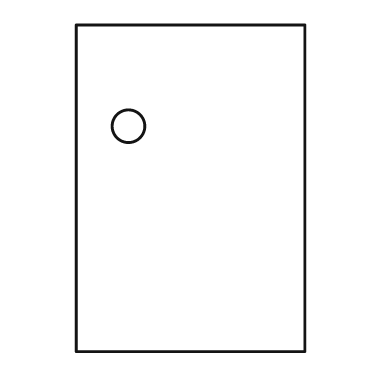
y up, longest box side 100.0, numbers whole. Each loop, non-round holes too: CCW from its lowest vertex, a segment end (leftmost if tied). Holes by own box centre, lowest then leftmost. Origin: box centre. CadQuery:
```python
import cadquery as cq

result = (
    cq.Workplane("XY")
    .moveTo(-35.0, -50.0)
    .lineTo(35.0, -50.0)
    .lineTo(35.0, 50.0)
    .lineTo(-35.0, 50.0)
    .close()
    .moveTo(-19.0, 19.0)
    .circle(5.0)
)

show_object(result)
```